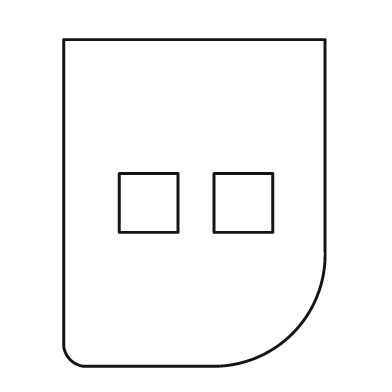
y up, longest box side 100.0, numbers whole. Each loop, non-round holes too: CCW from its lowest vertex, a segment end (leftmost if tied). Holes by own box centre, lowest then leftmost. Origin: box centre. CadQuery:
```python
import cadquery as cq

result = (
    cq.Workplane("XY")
    .moveTo(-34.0, -50.0)
    .lineTo(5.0, -50.0)
    .threePointArc((30.0, -40.0), (40.0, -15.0))
    .lineTo(40.0, 50.0)
    .lineTo(-40.0, 50.0)
    .lineTo(-40.0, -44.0)
    .threePointArc((-38.0, -48.0), (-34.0, -50.0))
    .close()
    .moveTo(-23.0, -9.0)
    .lineTo(-5.0, -9.0)
    .lineTo(-5.0, 9.0)
    .lineTo(-23.0, 9.0)
    .close()
    .moveTo(6.0, -9.0)
    .lineTo(24.0, -9.0)
    .lineTo(24.0, 9.0)
    .lineTo(6.0, 9.0)
    .close()
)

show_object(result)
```